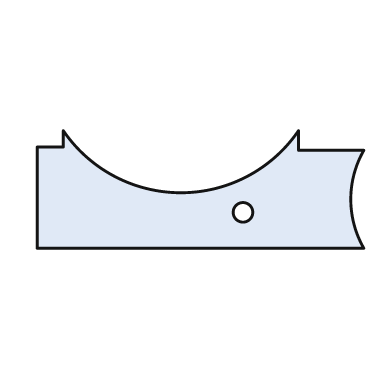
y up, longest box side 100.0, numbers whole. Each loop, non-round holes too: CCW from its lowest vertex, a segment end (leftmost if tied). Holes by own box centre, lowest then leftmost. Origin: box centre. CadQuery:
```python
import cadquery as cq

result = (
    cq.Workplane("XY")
    .moveTo(-50.0, -18.0)
    .lineTo(50.0, -18.0)
    .threePointArc((46.0, -3.0), (50.0, 12.0))
    .lineTo(30.0, 12.0)
    .lineTo(30.0, 18.0)
    .threePointArc((-6.0, -1.0), (-42.0, 18.0))
    .lineTo(-42.0, 13.0)
    .lineTo(-50.0, 13.0)
    .close()
    .moveTo(13.0, -7.0)
    .circle(3.0)
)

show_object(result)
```